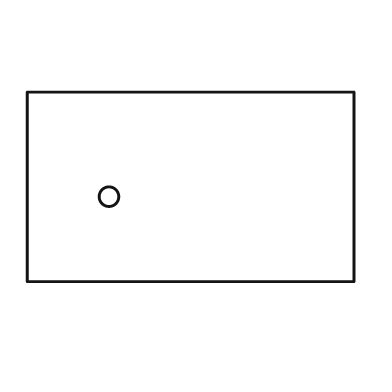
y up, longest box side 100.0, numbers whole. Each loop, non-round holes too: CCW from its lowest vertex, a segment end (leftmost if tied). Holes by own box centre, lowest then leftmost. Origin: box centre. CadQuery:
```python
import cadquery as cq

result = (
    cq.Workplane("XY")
    .moveTo(-50.0, -29.0)
    .lineTo(50.0, -29.0)
    .lineTo(50.0, 29.0)
    .lineTo(-50.0, 29.0)
    .close()
    .moveTo(-25.0, -3.0)
    .circle(3.0)
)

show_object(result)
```